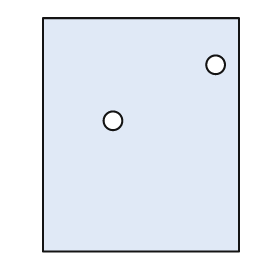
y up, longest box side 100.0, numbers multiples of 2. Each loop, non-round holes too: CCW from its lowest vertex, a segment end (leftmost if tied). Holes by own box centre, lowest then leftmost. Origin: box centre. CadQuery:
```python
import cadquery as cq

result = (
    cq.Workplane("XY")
    .moveTo(-42.0, -50.0)
    .lineTo(42.0, -50.0)
    .lineTo(42.0, 50.0)
    .lineTo(-42.0, 50.0)
    .close()
    .moveTo(-12.0, 6.0)
    .circle(4.0)
    .moveTo(32.0, 30.0)
    .circle(4.0)
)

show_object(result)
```